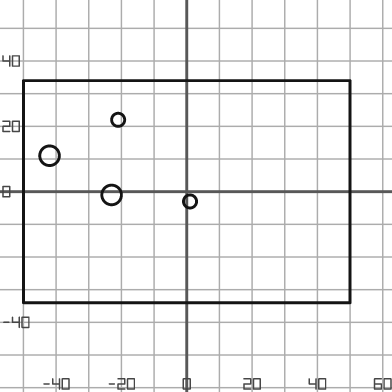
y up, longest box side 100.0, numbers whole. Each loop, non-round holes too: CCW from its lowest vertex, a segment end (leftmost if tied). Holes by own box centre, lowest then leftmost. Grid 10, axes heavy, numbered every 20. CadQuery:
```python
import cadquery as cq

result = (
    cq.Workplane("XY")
    .moveTo(-50.0, -34.0)
    .lineTo(50.0, -34.0)
    .lineTo(50.0, 34.0)
    .lineTo(-50.0, 34.0)
    .close()
    .moveTo(1.0, -3.0)
    .circle(2.0)
    .moveTo(-23.0, -1.0)
    .circle(3.0)
    .moveTo(-42.0, 11.0)
    .circle(3.0)
    .moveTo(-21.0, 22.0)
    .circle(2.0)
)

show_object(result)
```